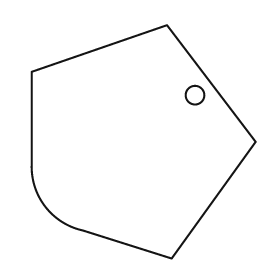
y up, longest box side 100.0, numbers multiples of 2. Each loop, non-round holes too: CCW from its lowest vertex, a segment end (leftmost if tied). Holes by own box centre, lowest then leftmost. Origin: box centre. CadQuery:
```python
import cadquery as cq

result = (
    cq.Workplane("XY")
    .moveTo(12.0, -50.0)
    .lineTo(48.0, 0.0)
    .lineTo(10.0, 50.0)
    .lineTo(-48.0, 30.0)
    .lineTo(-48.0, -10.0)
    .threePointArc((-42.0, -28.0), (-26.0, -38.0))
    .close()
    .moveTo(22.0, 20.0)
    .circle(4.0)
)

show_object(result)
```